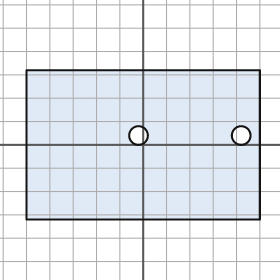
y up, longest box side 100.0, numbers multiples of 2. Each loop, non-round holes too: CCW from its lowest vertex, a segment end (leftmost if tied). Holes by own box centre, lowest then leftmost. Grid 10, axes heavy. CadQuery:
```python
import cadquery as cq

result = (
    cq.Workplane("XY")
    .moveTo(-50.0, -32.0)
    .lineTo(50.0, -32.0)
    .lineTo(50.0, 32.0)
    .lineTo(-50.0, 32.0)
    .close()
    .moveTo(-2.0, 4.0)
    .circle(4.0)
    .moveTo(42.0, 4.0)
    .circle(4.0)
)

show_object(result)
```